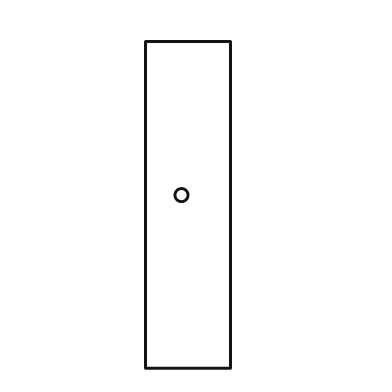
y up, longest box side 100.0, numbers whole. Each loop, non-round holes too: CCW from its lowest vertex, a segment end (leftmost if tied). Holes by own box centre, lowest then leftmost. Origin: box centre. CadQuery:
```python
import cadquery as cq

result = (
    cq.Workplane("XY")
    .moveTo(-13.0, -50.0)
    .lineTo(13.0, -50.0)
    .lineTo(13.0, 50.0)
    .lineTo(-13.0, 50.0)
    .close()
    .moveTo(-2.0, 3.0)
    .circle(2.0)
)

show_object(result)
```